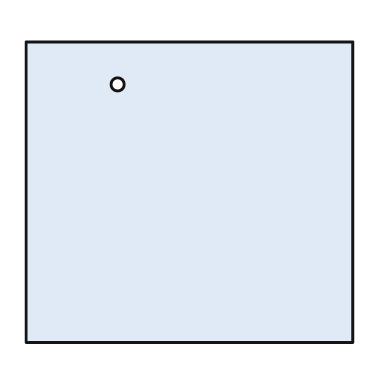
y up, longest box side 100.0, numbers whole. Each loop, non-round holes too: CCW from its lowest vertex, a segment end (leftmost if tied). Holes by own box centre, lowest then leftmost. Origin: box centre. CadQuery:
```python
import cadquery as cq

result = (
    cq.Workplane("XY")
    .moveTo(-50.0, -46.0)
    .lineTo(50.0, -46.0)
    .lineTo(50.0, 46.0)
    .lineTo(-50.0, 46.0)
    .close()
    .moveTo(-22.0, 33.0)
    .circle(2.0)
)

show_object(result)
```